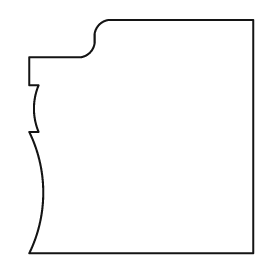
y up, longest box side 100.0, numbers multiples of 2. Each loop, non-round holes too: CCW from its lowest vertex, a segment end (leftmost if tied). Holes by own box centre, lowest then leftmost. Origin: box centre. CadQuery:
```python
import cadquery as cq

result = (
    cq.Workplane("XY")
    .moveTo(-48.0, -50.0)
    .lineTo(48.0, -50.0)
    .lineTo(48.0, 50.0)
    .lineTo(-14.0, 50.0)
    .threePointArc((-18.0, 48.0), (-20.0, 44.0))
    .lineTo(-20.0, 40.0)
    .threePointArc((-22.0, 36.0), (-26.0, 34.0))
    .lineTo(-48.0, 34.0)
    .lineTo(-48.0, 22.0)
    .lineTo(-44.0, 22.0)
    .threePointArc((-46.0, 12.0), (-44.0, 2.0))
    .lineTo(-48.0, 2.0)
    .threePointArc((-42.0, -24.0), (-48.0, -50.0))
    .close()
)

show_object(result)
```